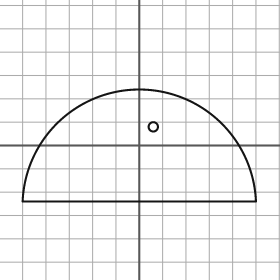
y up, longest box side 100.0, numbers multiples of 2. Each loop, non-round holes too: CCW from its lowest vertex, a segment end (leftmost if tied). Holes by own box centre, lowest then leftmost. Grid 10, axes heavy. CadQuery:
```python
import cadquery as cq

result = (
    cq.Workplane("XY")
    .moveTo(-50.0, -24.0)
    .lineTo(50.0, -24.0)
    .threePointArc((0.0, 24.0), (-50.0, -24.0))
    .close()
    .moveTo(6.0, 8.0)
    .circle(2.0)
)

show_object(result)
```